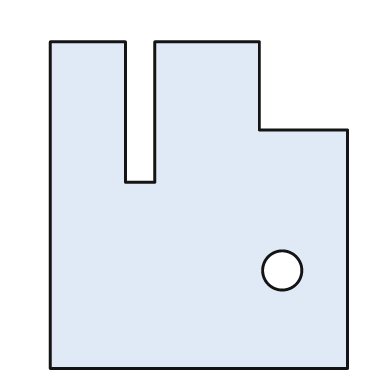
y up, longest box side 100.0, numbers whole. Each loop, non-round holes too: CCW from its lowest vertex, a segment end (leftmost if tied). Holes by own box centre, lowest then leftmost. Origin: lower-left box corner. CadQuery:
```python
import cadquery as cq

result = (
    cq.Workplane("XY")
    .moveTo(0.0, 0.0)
    .lineTo(91.0, 0.0)
    .lineTo(91.0, 73.0)
    .lineTo(64.0, 73.0)
    .lineTo(64.0, 100.0)
    .lineTo(32.0, 100.0)
    .lineTo(32.0, 57.0)
    .lineTo(23.0, 57.0)
    .lineTo(23.0, 100.0)
    .lineTo(0.0, 100.0)
    .close()
    .moveTo(71.0, 30.0)
    .circle(6.0)
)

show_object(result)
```